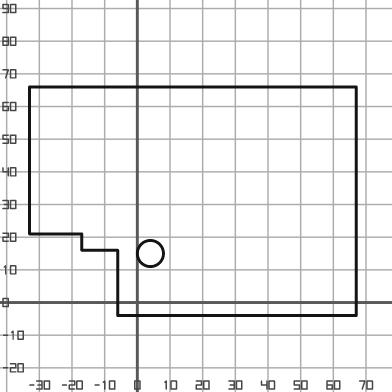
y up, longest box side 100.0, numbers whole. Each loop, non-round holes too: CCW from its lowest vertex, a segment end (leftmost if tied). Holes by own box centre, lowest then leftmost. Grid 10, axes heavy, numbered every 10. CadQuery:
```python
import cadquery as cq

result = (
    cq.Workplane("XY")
    .moveTo(-6.0, -4.0)
    .lineTo(67.0, -4.0)
    .lineTo(67.0, 66.0)
    .lineTo(-33.0, 66.0)
    .lineTo(-33.0, 21.0)
    .lineTo(-17.0, 21.0)
    .lineTo(-17.0, 16.0)
    .lineTo(-6.0, 16.0)
    .close()
    .moveTo(4.0, 15.0)
    .circle(4.0)
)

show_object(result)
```